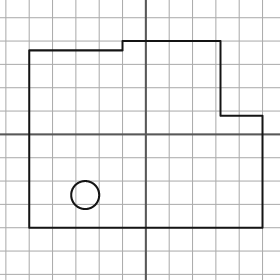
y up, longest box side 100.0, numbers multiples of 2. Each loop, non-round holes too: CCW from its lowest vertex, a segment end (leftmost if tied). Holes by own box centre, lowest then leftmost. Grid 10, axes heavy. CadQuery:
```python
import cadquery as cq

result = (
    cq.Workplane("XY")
    .moveTo(-50.0, -40.0)
    .lineTo(50.0, -40.0)
    .lineTo(50.0, 8.0)
    .lineTo(32.0, 8.0)
    .lineTo(32.0, 40.0)
    .lineTo(-10.0, 40.0)
    .lineTo(-10.0, 36.0)
    .lineTo(-50.0, 36.0)
    .close()
    .moveTo(-26.0, -26.0)
    .circle(6.0)
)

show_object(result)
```